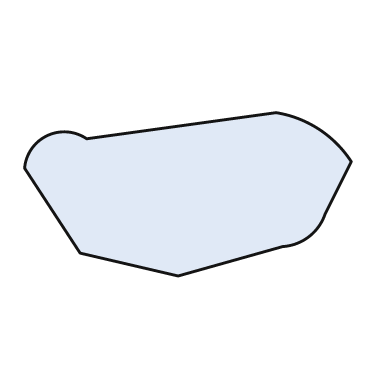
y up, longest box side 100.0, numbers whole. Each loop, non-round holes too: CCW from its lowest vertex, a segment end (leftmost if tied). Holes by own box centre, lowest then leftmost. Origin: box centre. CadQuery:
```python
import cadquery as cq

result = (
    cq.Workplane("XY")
    .moveTo(-3.0, -25.0)
    .lineTo(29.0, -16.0)
    .threePointArc((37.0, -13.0), (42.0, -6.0))
    .lineTo(50.0, 10.0)
    .threePointArc((40.0, 20.0), (27.0, 25.0))
    .lineTo(-31.0, 17.0)
    .threePointArc((-43.0, 18.0), (-50.0, 8.0))
    .lineTo(-33.0, -18.0)
    .close()
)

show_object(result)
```